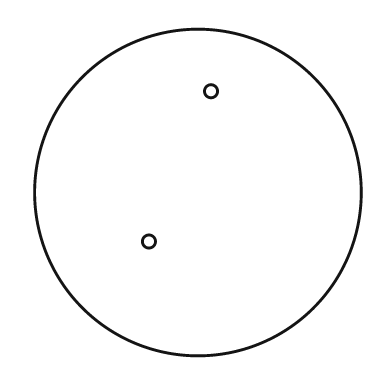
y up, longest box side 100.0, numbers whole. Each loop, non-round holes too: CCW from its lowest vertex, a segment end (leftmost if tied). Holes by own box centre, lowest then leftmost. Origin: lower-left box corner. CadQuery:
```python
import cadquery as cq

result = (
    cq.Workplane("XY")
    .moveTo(50.0, 50.0)
    .circle(50.0)
    .moveTo(35.0, 35.0)
    .circle(2.0)
    .moveTo(54.0, 81.0)
    .circle(2.0)
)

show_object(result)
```